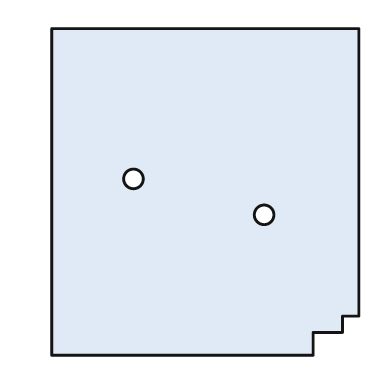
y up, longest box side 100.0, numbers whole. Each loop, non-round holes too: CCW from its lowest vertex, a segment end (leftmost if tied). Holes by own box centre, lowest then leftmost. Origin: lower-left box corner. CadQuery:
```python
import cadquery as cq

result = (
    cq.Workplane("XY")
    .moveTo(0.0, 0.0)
    .lineTo(80.0, 0.0)
    .lineTo(80.0, 7.0)
    .lineTo(89.0, 7.0)
    .lineTo(89.0, 12.0)
    .lineTo(94.0, 12.0)
    .lineTo(94.0, 100.0)
    .lineTo(0.0, 100.0)
    .close()
    .moveTo(65.0, 43.0)
    .circle(3.0)
    .moveTo(25.0, 54.0)
    .circle(3.0)
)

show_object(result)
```